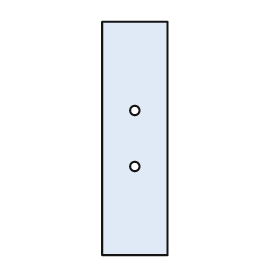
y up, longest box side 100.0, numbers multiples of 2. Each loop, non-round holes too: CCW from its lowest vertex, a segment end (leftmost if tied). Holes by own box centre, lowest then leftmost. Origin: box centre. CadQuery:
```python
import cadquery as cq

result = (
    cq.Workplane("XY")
    .moveTo(-14.0, -50.0)
    .lineTo(14.0, -50.0)
    .lineTo(14.0, 50.0)
    .lineTo(-14.0, 50.0)
    .close()
    .moveTo(0.0, -12.0)
    .circle(2.0)
    .moveTo(0.0, 12.0)
    .circle(2.0)
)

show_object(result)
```